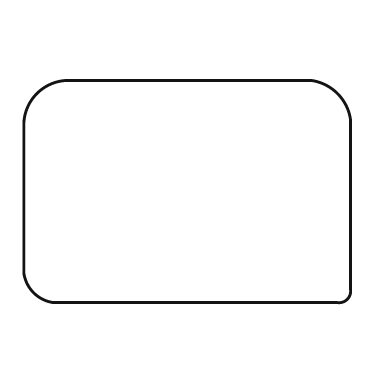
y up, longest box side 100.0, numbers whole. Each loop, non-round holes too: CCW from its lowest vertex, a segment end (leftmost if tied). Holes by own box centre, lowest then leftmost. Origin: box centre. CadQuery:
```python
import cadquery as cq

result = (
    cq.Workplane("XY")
    .moveTo(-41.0, -34.0)
    .lineTo(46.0, -34.0)
    .threePointArc((49.0, -33.0), (50.0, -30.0))
    .lineTo(50.0, 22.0)
    .threePointArc((46.0, 30.0), (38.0, 34.0))
    .lineTo(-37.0, 34.0)
    .threePointArc((-46.0, 30.0), (-50.0, 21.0))
    .lineTo(-50.0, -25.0)
    .threePointArc((-47.0, -31.0), (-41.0, -34.0))
    .close()
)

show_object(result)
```